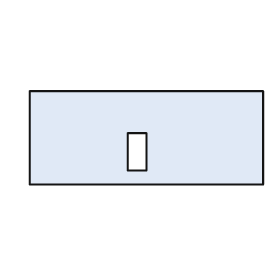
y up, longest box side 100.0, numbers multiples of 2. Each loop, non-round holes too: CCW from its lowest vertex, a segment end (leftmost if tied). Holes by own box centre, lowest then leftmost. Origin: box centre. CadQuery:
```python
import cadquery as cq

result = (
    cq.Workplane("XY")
    .moveTo(-50.0, -20.0)
    .lineTo(50.0, -20.0)
    .lineTo(50.0, 20.0)
    .lineTo(-50.0, 20.0)
    .close()
    .moveTo(-8.0, -14.0)
    .lineTo(0.0, -14.0)
    .lineTo(0.0, 2.0)
    .lineTo(-8.0, 2.0)
    .close()
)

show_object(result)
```